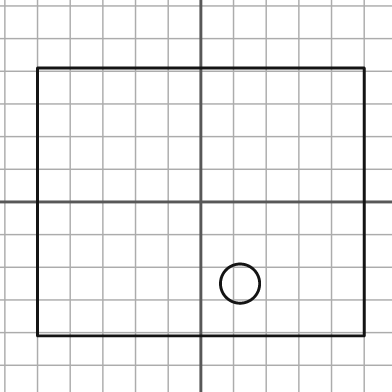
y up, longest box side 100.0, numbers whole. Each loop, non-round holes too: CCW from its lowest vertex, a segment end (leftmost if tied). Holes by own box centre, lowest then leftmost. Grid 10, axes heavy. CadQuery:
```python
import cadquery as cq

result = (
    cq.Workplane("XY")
    .moveTo(-50.0, -41.0)
    .lineTo(50.0, -41.0)
    .lineTo(50.0, 41.0)
    .lineTo(-50.0, 41.0)
    .close()
    .moveTo(12.0, -25.0)
    .circle(6.0)
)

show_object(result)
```